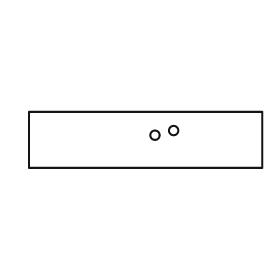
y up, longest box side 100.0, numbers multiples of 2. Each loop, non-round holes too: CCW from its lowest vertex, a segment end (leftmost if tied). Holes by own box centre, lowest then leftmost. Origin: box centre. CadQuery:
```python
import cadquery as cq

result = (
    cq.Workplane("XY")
    .moveTo(-50.0, -12.0)
    .lineTo(50.0, -12.0)
    .lineTo(50.0, 12.0)
    .lineTo(-50.0, 12.0)
    .close()
    .moveTo(4.0, 2.0)
    .circle(2.0)
    .moveTo(12.0, 4.0)
    .circle(2.0)
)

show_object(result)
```